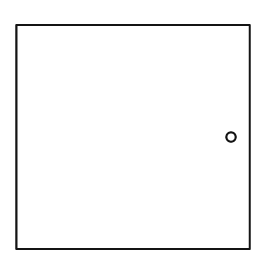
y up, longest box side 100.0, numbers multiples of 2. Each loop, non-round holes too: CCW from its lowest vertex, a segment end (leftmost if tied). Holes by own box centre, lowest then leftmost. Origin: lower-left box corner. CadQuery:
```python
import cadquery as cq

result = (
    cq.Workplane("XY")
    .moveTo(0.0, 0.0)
    .lineTo(100.0, 0.0)
    .lineTo(100.0, 96.0)
    .lineTo(0.0, 96.0)
    .close()
    .moveTo(92.0, 48.0)
    .circle(2.0)
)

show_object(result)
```